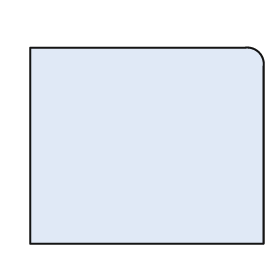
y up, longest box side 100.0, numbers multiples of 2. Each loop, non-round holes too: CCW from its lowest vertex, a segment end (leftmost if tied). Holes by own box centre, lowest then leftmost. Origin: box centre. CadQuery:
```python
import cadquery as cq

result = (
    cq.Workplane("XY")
    .moveTo(-50.0, -42.0)
    .lineTo(50.0, -42.0)
    .lineTo(50.0, 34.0)
    .threePointArc((48.0, 40.0), (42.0, 42.0))
    .lineTo(-50.0, 42.0)
    .close()
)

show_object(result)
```